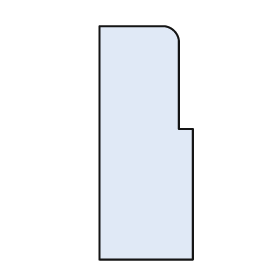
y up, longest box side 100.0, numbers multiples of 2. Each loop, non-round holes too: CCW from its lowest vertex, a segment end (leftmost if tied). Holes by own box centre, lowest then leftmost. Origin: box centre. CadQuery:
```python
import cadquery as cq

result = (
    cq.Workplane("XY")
    .moveTo(-20.0, -50.0)
    .lineTo(20.0, -50.0)
    .lineTo(20.0, 6.0)
    .lineTo(14.0, 6.0)
    .lineTo(14.0, 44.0)
    .threePointArc((12.0, 48.0), (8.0, 50.0))
    .lineTo(-20.0, 50.0)
    .close()
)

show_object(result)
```